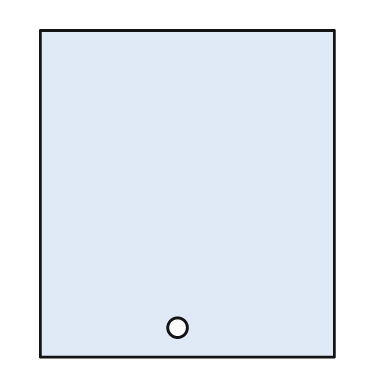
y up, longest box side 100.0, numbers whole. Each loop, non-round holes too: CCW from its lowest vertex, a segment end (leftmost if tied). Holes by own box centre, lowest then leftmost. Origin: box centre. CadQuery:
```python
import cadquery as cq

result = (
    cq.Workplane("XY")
    .moveTo(-45.0, -50.0)
    .lineTo(45.0, -50.0)
    .lineTo(45.0, 50.0)
    .lineTo(-45.0, 50.0)
    .close()
    .moveTo(-3.0, -41.0)
    .circle(3.0)
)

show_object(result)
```